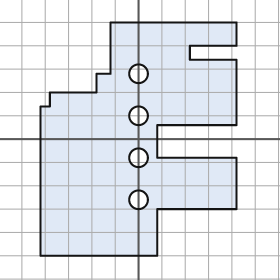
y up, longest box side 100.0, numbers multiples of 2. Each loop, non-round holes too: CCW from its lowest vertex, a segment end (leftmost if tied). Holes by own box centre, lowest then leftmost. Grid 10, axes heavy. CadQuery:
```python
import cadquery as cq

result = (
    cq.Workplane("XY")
    .moveTo(-42.0, -50.0)
    .lineTo(8.0, -50.0)
    .lineTo(8.0, -30.0)
    .lineTo(42.0, -30.0)
    .lineTo(42.0, -8.0)
    .lineTo(8.0, -8.0)
    .lineTo(8.0, 6.0)
    .lineTo(42.0, 6.0)
    .lineTo(42.0, 34.0)
    .lineTo(22.0, 34.0)
    .lineTo(22.0, 40.0)
    .lineTo(42.0, 40.0)
    .lineTo(42.0, 50.0)
    .lineTo(-12.0, 50.0)
    .lineTo(-12.0, 28.0)
    .lineTo(-18.0, 28.0)
    .lineTo(-18.0, 20.0)
    .lineTo(-38.0, 20.0)
    .lineTo(-38.0, 14.0)
    .lineTo(-42.0, 14.0)
    .close()
    .moveTo(0.0, -26.0)
    .circle(4.0)
    .moveTo(0.0, -8.0)
    .circle(4.0)
    .moveTo(0.0, 10.0)
    .circle(4.0)
    .moveTo(0.0, 28.0)
    .circle(4.0)
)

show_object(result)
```